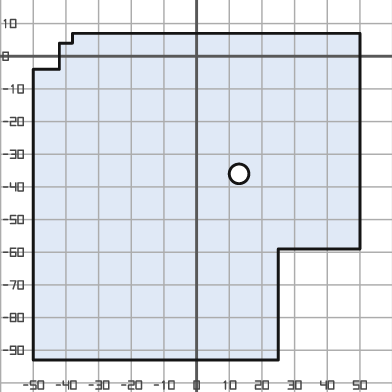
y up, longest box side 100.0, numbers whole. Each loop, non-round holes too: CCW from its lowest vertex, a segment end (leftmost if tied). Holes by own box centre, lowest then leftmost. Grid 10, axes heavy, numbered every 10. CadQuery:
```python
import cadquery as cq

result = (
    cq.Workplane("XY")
    .moveTo(-50.0, -93.0)
    .lineTo(25.0, -93.0)
    .lineTo(25.0, -59.0)
    .lineTo(50.0, -59.0)
    .lineTo(50.0, 7.0)
    .lineTo(-38.0, 7.0)
    .lineTo(-38.0, 4.0)
    .lineTo(-42.0, 4.0)
    .lineTo(-42.0, -4.0)
    .lineTo(-50.0, -4.0)
    .close()
    .moveTo(13.0, -36.0)
    .circle(3.0)
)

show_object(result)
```